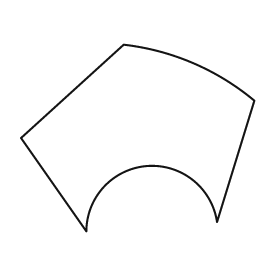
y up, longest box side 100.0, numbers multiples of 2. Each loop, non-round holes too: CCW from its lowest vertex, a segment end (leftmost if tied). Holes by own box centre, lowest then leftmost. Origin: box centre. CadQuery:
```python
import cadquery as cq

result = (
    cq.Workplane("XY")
    .moveTo(-22.0, -40.0)
    .threePointArc((4.0, -12.0), (34.0, -36.0))
    .lineTo(50.0, 16.0)
    .threePointArc((24.0, 32.0), (-6.0, 40.0))
    .lineTo(-50.0, 0.0)
    .close()
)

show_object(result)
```